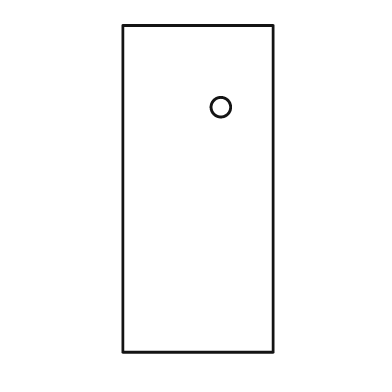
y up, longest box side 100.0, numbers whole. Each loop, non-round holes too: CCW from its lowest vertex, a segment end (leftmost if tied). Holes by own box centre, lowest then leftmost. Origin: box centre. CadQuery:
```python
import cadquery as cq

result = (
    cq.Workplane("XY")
    .moveTo(-23.0, -50.0)
    .lineTo(23.0, -50.0)
    .lineTo(23.0, 50.0)
    .lineTo(-23.0, 50.0)
    .close()
    .moveTo(7.0, 25.0)
    .circle(3.0)
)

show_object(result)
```